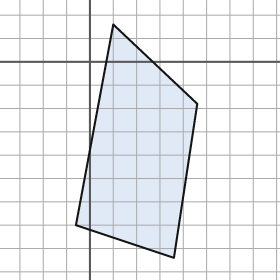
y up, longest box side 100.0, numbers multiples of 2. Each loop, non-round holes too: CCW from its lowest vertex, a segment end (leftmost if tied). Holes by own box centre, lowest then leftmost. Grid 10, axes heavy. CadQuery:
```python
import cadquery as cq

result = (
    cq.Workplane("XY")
    .moveTo(36.0, -84.0)
    .lineTo(46.0, -18.0)
    .lineTo(10.0, 16.0)
    .lineTo(-6.0, -70.0)
    .close()
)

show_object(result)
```